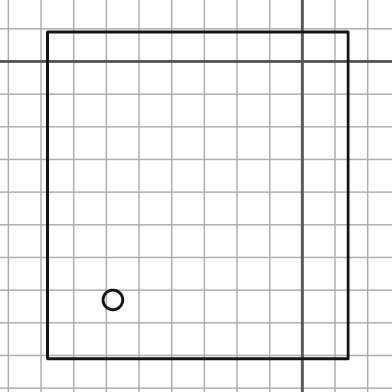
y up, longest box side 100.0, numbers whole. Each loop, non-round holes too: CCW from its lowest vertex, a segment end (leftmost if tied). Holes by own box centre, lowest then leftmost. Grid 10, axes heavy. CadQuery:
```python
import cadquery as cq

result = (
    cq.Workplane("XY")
    .moveTo(-78.0, -91.0)
    .lineTo(14.0, -91.0)
    .lineTo(14.0, 9.0)
    .lineTo(-78.0, 9.0)
    .close()
    .moveTo(-58.0, -73.0)
    .circle(3.0)
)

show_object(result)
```